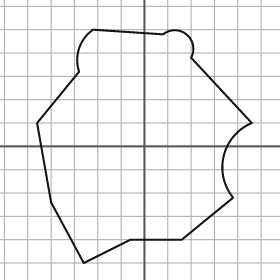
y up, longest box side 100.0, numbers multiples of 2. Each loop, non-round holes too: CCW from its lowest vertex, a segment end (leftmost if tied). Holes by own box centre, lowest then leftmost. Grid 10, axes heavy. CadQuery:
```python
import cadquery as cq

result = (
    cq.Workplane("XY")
    .moveTo(-26.0, -50.0)
    .lineTo(-6.0, -40.0)
    .lineTo(16.0, -40.0)
    .lineTo(38.0, -22.0)
    .threePointArc((34.0, -4.0), (46.0, 10.0))
    .lineTo(20.0, 38.0)
    .threePointArc((18.0, 48.0), (8.0, 48.0))
    .lineTo(-22.0, 50.0)
    .threePointArc((-28.0, 42.0), (-28.0, 32.0))
    .lineTo(-46.0, 10.0)
    .lineTo(-40.0, -24.0)
    .close()
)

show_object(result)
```